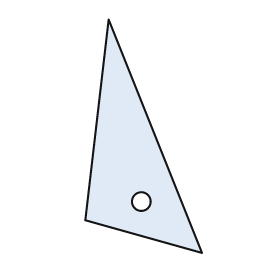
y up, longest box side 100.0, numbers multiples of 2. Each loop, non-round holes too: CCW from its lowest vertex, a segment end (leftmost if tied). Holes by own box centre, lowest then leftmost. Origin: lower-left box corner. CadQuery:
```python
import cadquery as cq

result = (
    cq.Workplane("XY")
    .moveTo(50.0, 0.0)
    .lineTo(10.0, 100.0)
    .lineTo(0.0, 14.0)
    .close()
    .moveTo(24.0, 22.0)
    .circle(4.0)
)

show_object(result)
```